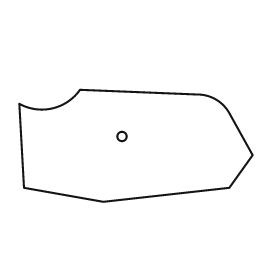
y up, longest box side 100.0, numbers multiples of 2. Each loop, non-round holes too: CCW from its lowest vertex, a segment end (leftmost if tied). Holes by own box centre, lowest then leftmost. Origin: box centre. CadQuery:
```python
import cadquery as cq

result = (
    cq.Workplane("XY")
    .moveTo(-14.0, -24.0)
    .lineTo(40.0, -18.0)
    .lineTo(50.0, -4.0)
    .lineTo(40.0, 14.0)
    .threePointArc((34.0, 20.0), (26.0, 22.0))
    .lineTo(-24.0, 24.0)
    .threePointArc((-36.0, 16.0), (-50.0, 18.0))
    .lineTo(-48.0, -18.0)
    .close()
    .moveTo(-6.0, 4.0)
    .circle(2.0)
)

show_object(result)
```